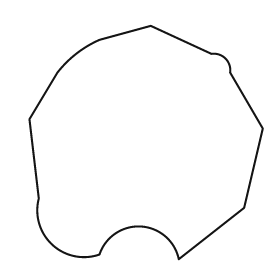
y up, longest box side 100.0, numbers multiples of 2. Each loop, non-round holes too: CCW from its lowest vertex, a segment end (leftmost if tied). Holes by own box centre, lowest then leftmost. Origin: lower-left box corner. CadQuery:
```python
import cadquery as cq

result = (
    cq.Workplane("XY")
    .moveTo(64.0, 0.0)
    .lineTo(92.0, 22.0)
    .lineTo(100.0, 56.0)
    .lineTo(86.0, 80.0)
    .threePointArc((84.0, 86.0), (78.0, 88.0))
    .lineTo(52.0, 100.0)
    .lineTo(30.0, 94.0)
    .threePointArc((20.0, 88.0), (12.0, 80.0))
    .lineTo(0.0, 60.0)
    .lineTo(4.0, 26.0)
    .threePointArc((10.0, 6.0), (30.0, 2.0))
    .threePointArc((48.0, 14.0), (64.0, 0.0))
    .close()
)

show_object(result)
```